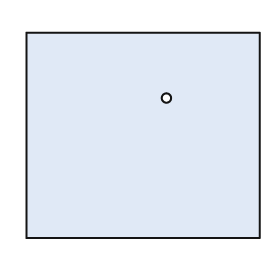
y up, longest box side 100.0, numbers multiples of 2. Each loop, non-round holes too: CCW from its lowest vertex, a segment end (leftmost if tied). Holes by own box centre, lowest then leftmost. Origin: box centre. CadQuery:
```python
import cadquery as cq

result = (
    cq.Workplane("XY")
    .moveTo(-50.0, -44.0)
    .lineTo(50.0, -44.0)
    .lineTo(50.0, 44.0)
    .lineTo(-50.0, 44.0)
    .close()
    .moveTo(10.0, 16.0)
    .circle(2.0)
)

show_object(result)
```